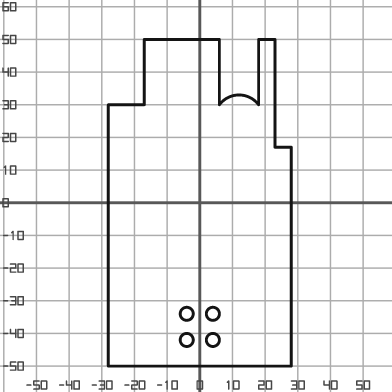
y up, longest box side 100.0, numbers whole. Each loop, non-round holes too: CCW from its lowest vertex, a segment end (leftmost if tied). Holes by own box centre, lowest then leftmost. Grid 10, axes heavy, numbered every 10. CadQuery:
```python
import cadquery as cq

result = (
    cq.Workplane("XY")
    .moveTo(-28.0, -50.0)
    .lineTo(28.0, -50.0)
    .lineTo(28.0, 17.0)
    .lineTo(23.0, 17.0)
    .lineTo(23.0, 50.0)
    .lineTo(18.0, 50.0)
    .lineTo(18.0, 30.0)
    .threePointArc((12.0, 33.0), (6.0, 30.0))
    .lineTo(6.0, 50.0)
    .lineTo(-17.0, 50.0)
    .lineTo(-17.0, 30.0)
    .lineTo(-28.0, 30.0)
    .close()
    .moveTo(-4.0, -42.0)
    .circle(2.0)
    .moveTo(4.0, -42.0)
    .circle(2.0)
    .moveTo(-4.0, -34.0)
    .circle(2.0)
    .moveTo(4.0, -34.0)
    .circle(2.0)
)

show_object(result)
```